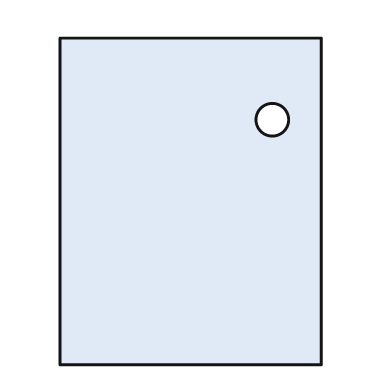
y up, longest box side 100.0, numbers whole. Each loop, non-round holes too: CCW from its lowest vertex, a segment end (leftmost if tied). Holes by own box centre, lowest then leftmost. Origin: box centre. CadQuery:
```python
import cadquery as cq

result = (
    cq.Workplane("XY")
    .moveTo(-40.0, -50.0)
    .lineTo(40.0, -50.0)
    .lineTo(40.0, 50.0)
    .lineTo(-40.0, 50.0)
    .close()
    .moveTo(25.0, 25.0)
    .circle(5.0)
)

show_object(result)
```